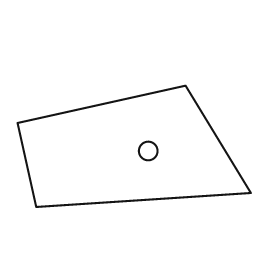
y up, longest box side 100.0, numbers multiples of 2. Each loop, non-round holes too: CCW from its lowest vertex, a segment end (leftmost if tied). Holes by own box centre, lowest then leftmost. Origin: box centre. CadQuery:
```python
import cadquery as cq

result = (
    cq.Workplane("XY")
    .moveTo(-42.0, -26.0)
    .lineTo(50.0, -20.0)
    .lineTo(22.0, 26.0)
    .lineTo(-50.0, 10.0)
    .close()
    .moveTo(6.0, -2.0)
    .circle(4.0)
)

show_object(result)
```